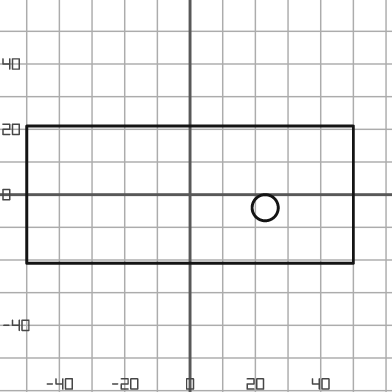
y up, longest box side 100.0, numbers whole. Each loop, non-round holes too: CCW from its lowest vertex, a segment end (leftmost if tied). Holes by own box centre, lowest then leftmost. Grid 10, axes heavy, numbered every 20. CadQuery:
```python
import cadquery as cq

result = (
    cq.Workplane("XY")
    .moveTo(-50.0, -21.0)
    .lineTo(50.0, -21.0)
    .lineTo(50.0, 21.0)
    .lineTo(-50.0, 21.0)
    .close()
    .moveTo(23.0, -4.0)
    .circle(4.0)
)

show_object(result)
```